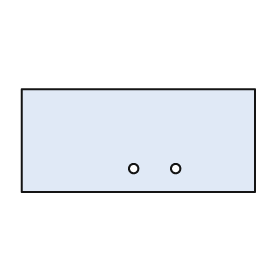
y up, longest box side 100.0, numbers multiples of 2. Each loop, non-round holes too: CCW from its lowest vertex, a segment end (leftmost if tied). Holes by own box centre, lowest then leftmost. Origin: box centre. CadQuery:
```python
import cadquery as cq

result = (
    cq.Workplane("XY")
    .moveTo(-50.0, -22.0)
    .lineTo(50.0, -22.0)
    .lineTo(50.0, 22.0)
    .lineTo(-50.0, 22.0)
    .close()
    .moveTo(-2.0, -12.0)
    .circle(2.0)
    .moveTo(16.0, -12.0)
    .circle(2.0)
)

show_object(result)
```